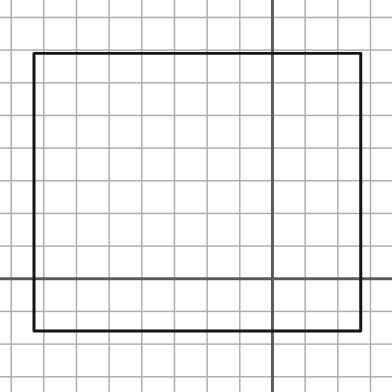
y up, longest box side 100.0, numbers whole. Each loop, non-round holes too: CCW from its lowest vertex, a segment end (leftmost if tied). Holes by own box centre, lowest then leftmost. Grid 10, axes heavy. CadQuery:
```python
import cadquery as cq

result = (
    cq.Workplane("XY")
    .moveTo(-73.0, -16.0)
    .lineTo(27.0, -16.0)
    .lineTo(27.0, 69.0)
    .lineTo(-73.0, 69.0)
    .close()
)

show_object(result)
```